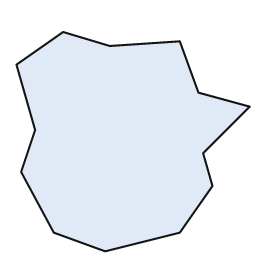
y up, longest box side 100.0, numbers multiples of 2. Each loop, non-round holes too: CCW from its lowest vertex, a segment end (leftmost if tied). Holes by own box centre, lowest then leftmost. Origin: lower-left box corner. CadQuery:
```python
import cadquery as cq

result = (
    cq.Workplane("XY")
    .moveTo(38.0, 0.0)
    .lineTo(70.0, 8.0)
    .lineTo(84.0, 28.0)
    .lineTo(80.0, 42.0)
    .lineTo(100.0, 62.0)
    .lineTo(78.0, 68.0)
    .lineTo(70.0, 90.0)
    .lineTo(40.0, 88.0)
    .lineTo(20.0, 94.0)
    .lineTo(0.0, 80.0)
    .lineTo(8.0, 52.0)
    .lineTo(2.0, 34.0)
    .lineTo(16.0, 8.0)
    .close()
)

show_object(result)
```